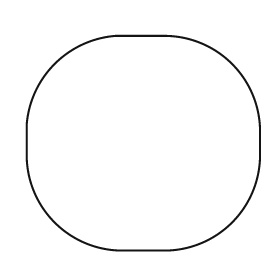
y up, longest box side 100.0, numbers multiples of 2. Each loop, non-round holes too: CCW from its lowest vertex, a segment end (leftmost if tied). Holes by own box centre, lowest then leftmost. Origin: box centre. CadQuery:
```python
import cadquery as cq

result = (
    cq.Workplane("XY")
    .moveTo(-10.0, -46.0)
    .lineTo(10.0, -46.0)
    .threePointArc((38.0, -34.0), (50.0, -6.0))
    .lineTo(50.0, 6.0)
    .threePointArc((38.0, 34.0), (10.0, 46.0))
    .lineTo(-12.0, 46.0)
    .threePointArc((-38.0, 34.0), (-50.0, 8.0))
    .lineTo(-50.0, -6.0)
    .threePointArc((-38.0, -34.0), (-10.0, -46.0))
    .close()
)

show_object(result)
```